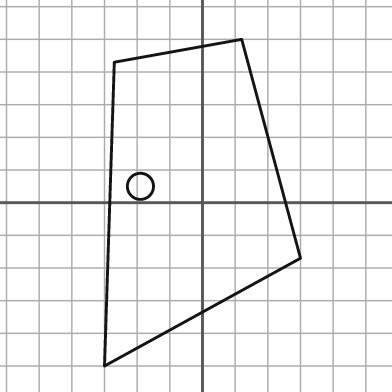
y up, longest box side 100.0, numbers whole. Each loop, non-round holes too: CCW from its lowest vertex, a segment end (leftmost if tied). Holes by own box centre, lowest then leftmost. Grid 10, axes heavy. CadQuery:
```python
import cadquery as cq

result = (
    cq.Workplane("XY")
    .moveTo(-30.0, -50.0)
    .lineTo(30.0, -17.0)
    .lineTo(12.0, 50.0)
    .lineTo(-27.0, 43.0)
    .close()
    .moveTo(-19.0, 5.0)
    .circle(4.0)
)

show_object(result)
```